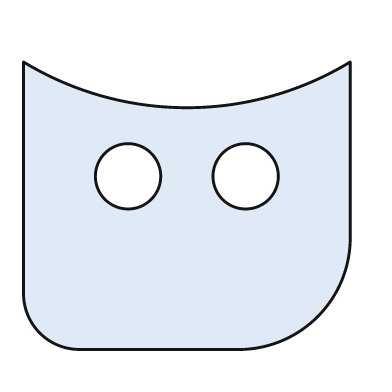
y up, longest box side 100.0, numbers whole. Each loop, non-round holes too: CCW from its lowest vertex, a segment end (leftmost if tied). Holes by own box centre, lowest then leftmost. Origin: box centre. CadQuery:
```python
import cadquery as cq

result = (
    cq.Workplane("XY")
    .moveTo(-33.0, -44.0)
    .lineTo(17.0, -44.0)
    .threePointArc((40.0, -34.0), (50.0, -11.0))
    .lineTo(50.0, 44.0)
    .threePointArc((0.0, 30.0), (-50.0, 44.0))
    .lineTo(-50.0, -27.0)
    .threePointArc((-45.0, -39.0), (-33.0, -44.0))
    .close()
    .moveTo(-18.0, 9.0)
    .circle(10.0)
    .moveTo(18.0, 9.0)
    .circle(10.0)
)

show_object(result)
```